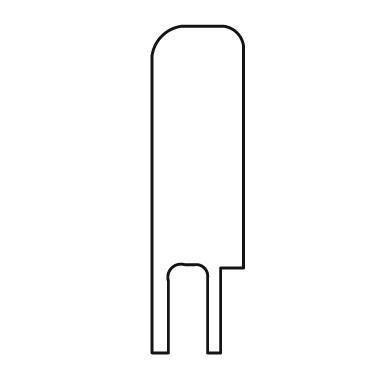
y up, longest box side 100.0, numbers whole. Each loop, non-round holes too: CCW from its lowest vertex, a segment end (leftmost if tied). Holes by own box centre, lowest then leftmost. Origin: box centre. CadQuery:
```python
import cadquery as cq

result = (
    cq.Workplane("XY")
    .moveTo(-14.0, -50.0)
    .lineTo(-9.0, -50.0)
    .lineTo(-9.0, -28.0)
    .threePointArc((-8.0, -24.0), (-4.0, -23.0))
    .lineTo(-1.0, -23.0)
    .threePointArc((2.0, -24.0), (3.0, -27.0))
    .lineTo(3.0, -50.0)
    .lineTo(7.0, -50.0)
    .lineTo(7.0, -24.0)
    .lineTo(14.0, -24.0)
    .lineTo(14.0, 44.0)
    .threePointArc((12.0, 48.0), (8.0, 50.0))
    .lineTo(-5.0, 50.0)
    .threePointArc((-11.0, 47.0), (-14.0, 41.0))
    .close()
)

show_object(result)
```